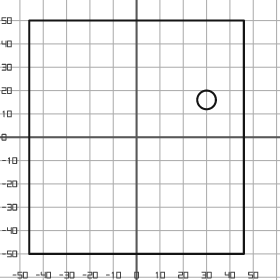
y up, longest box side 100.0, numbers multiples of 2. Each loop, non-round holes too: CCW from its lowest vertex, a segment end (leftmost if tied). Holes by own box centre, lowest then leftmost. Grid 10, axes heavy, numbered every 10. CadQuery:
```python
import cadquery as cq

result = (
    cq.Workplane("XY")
    .moveTo(-46.0, -50.0)
    .lineTo(46.0, -50.0)
    .lineTo(46.0, 50.0)
    .lineTo(-46.0, 50.0)
    .close()
    .moveTo(30.0, 16.0)
    .circle(4.0)
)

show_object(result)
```